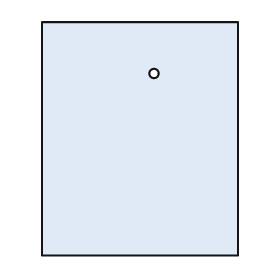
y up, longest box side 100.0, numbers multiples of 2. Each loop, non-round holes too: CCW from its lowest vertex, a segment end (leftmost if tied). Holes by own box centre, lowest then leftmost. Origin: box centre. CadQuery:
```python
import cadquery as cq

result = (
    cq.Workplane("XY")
    .moveTo(-42.0, -50.0)
    .lineTo(42.0, -50.0)
    .lineTo(42.0, 50.0)
    .lineTo(-42.0, 50.0)
    .close()
    .moveTo(6.0, 28.0)
    .circle(2.0)
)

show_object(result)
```